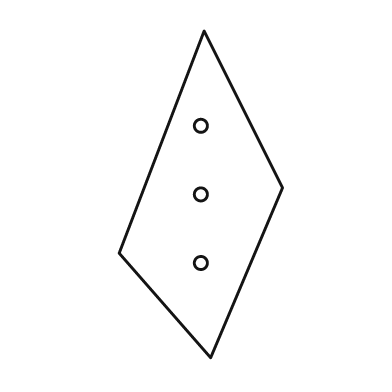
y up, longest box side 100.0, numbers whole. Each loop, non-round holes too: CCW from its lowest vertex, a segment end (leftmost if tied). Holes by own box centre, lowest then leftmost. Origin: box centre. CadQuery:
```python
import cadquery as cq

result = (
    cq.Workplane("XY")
    .moveTo(3.0, -50.0)
    .lineTo(25.0, 2.0)
    .lineTo(1.0, 50.0)
    .lineTo(-25.0, -18.0)
    .close()
    .moveTo(0.0, -21.0)
    .circle(2.0)
    .moveTo(0.0, 0.0)
    .circle(2.0)
    .moveTo(0.0, 21.0)
    .circle(2.0)
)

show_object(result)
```